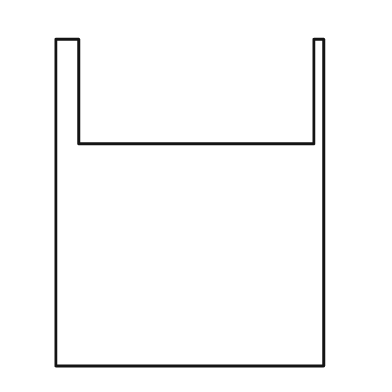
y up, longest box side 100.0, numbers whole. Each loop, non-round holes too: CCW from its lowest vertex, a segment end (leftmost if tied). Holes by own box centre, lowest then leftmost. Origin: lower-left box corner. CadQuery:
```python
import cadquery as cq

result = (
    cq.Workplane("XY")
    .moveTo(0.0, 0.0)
    .lineTo(82.0, 0.0)
    .lineTo(82.0, 100.0)
    .lineTo(79.0, 100.0)
    .lineTo(79.0, 68.0)
    .lineTo(7.0, 68.0)
    .lineTo(7.0, 100.0)
    .lineTo(0.0, 100.0)
    .close()
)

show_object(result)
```